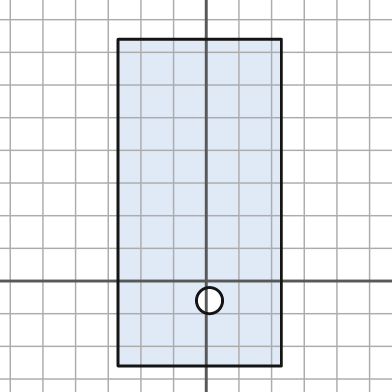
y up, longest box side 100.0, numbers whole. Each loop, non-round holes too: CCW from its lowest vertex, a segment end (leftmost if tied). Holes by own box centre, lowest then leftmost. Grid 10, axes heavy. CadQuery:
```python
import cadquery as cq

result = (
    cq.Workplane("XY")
    .moveTo(-27.0, -26.0)
    .lineTo(23.0, -26.0)
    .lineTo(23.0, 74.0)
    .lineTo(-27.0, 74.0)
    .close()
    .moveTo(1.0, -6.0)
    .circle(4.0)
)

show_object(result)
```